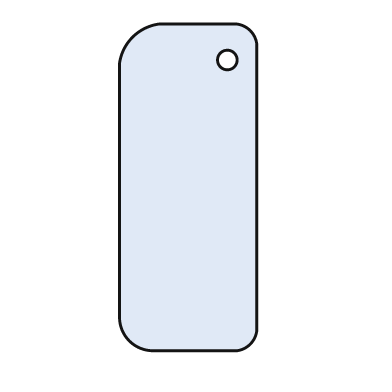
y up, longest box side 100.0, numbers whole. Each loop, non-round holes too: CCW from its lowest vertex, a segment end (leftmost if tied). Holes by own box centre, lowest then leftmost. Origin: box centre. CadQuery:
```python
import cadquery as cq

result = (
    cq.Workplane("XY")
    .moveTo(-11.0, -50.0)
    .lineTo(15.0, -50.0)
    .threePointArc((19.0, -48.0), (21.0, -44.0))
    .lineTo(21.0, 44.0)
    .threePointArc((19.0, 48.0), (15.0, 50.0))
    .lineTo(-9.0, 50.0)
    .threePointArc((-17.0, 46.0), (-21.0, 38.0))
    .lineTo(-21.0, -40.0)
    .threePointArc((-18.0, -47.0), (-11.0, -50.0))
    .close()
    .moveTo(12.0, 39.0)
    .circle(3.0)
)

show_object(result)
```